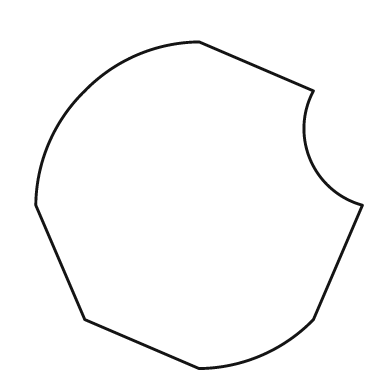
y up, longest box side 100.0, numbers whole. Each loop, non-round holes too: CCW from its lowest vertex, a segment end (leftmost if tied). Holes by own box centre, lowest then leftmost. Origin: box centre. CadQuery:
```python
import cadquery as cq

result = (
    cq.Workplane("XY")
    .moveTo(0.0, -50.0)
    .threePointArc((19.0, -46.0), (35.0, -35.0))
    .lineTo(50.0, 0.0)
    .threePointArc((34.0, 14.0), (35.0, 35.0))
    .lineTo(0.0, 50.0)
    .threePointArc((-19.0, 46.0), (-35.0, 35.0))
    .threePointArc((-46.0, 19.0), (-50.0, 0.0))
    .lineTo(-35.0, -35.0)
    .close()
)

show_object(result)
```